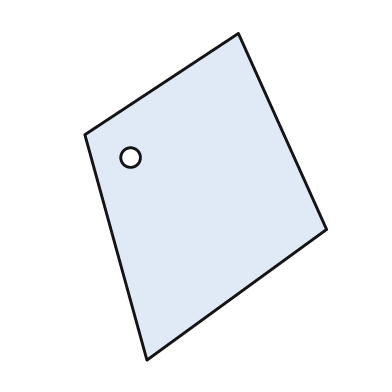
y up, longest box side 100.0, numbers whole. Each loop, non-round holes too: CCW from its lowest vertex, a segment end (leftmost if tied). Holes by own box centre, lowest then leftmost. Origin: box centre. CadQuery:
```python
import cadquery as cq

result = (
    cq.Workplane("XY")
    .moveTo(-18.0, -50.0)
    .lineTo(37.0, -10.0)
    .lineTo(10.0, 50.0)
    .lineTo(-37.0, 19.0)
    .close()
    .moveTo(-23.0, 12.0)
    .circle(3.0)
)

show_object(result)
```